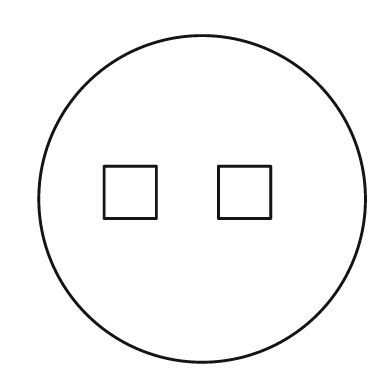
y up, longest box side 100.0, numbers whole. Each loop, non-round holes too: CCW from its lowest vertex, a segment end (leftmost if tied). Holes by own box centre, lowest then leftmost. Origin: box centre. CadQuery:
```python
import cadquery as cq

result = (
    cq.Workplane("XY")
    .moveTo(0.0, 0.0)
    .circle(50.0)
    .moveTo(-30.0, -6.0)
    .lineTo(-14.0, -6.0)
    .lineTo(-14.0, 10.0)
    .lineTo(-30.0, 10.0)
    .close()
    .moveTo(5.0, -6.0)
    .lineTo(21.0, -6.0)
    .lineTo(21.0, 10.0)
    .lineTo(5.0, 10.0)
    .close()
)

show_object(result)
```